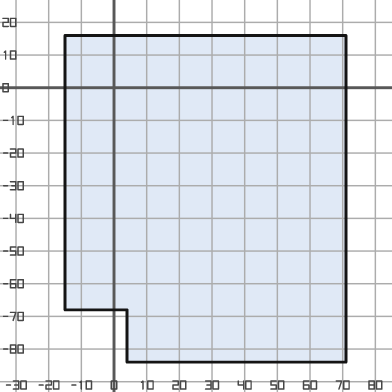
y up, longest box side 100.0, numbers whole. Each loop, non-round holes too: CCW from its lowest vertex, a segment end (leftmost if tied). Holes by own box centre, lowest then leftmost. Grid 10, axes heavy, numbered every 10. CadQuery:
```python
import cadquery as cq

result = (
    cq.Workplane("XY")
    .moveTo(4.0, -84.0)
    .lineTo(71.0, -84.0)
    .lineTo(71.0, 16.0)
    .lineTo(-15.0, 16.0)
    .lineTo(-15.0, -68.0)
    .lineTo(4.0, -68.0)
    .close()
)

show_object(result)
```